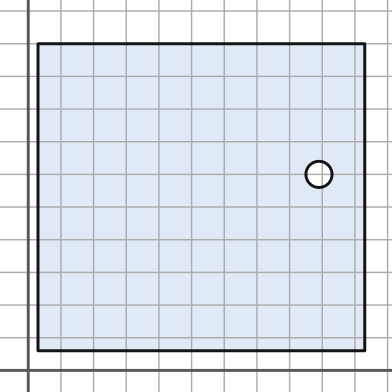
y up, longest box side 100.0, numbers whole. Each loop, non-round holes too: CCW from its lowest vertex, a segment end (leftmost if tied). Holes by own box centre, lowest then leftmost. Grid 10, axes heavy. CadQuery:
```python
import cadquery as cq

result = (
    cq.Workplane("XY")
    .moveTo(3.0, 6.0)
    .lineTo(103.0, 6.0)
    .lineTo(103.0, 100.0)
    .lineTo(3.0, 100.0)
    .close()
    .moveTo(89.0, 60.0)
    .circle(4.0)
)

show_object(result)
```